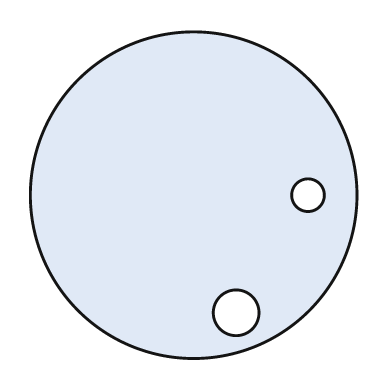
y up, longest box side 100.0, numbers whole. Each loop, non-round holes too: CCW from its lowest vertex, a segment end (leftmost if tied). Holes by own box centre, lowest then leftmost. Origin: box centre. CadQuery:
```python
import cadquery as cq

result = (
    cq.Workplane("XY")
    .moveTo(0.0, 0.0)
    .circle(50.0)
    .moveTo(13.0, -36.0)
    .circle(7.0)
    .moveTo(35.0, 0.0)
    .circle(5.0)
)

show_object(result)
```